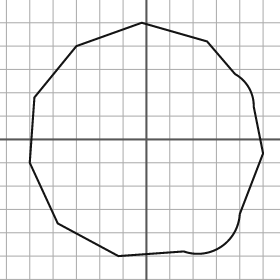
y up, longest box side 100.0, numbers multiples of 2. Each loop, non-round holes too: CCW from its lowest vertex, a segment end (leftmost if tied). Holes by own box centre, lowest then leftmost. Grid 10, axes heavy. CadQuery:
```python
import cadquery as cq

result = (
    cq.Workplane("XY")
    .moveTo(-12.0, -50.0)
    .lineTo(16.0, -48.0)
    .threePointArc((32.0, -46.0), (40.0, -32.0))
    .lineTo(50.0, -6.0)
    .lineTo(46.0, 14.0)
    .threePointArc((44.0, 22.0), (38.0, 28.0))
    .lineTo(26.0, 42.0)
    .lineTo(-2.0, 50.0)
    .lineTo(-30.0, 40.0)
    .lineTo(-48.0, 18.0)
    .lineTo(-50.0, -10.0)
    .lineTo(-38.0, -36.0)
    .close()
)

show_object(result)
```